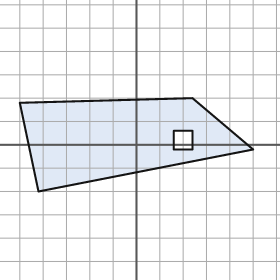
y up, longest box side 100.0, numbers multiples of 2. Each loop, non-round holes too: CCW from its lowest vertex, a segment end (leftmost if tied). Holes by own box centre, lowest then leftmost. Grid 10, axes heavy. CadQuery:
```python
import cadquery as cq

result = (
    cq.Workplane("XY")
    .moveTo(-42.0, -20.0)
    .lineTo(50.0, -2.0)
    .lineTo(24.0, 20.0)
    .lineTo(-50.0, 18.0)
    .close()
    .moveTo(16.0, -2.0)
    .lineTo(24.0, -2.0)
    .lineTo(24.0, 6.0)
    .lineTo(16.0, 6.0)
    .close()
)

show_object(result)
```